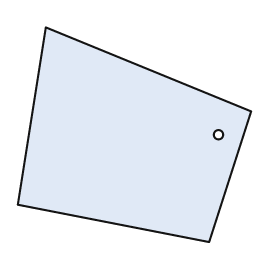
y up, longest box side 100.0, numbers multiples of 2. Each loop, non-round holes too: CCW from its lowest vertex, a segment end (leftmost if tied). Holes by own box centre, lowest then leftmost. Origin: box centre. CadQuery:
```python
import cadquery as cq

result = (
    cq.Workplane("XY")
    .moveTo(32.0, -46.0)
    .lineTo(50.0, 10.0)
    .lineTo(-38.0, 46.0)
    .lineTo(-50.0, -30.0)
    .close()
    .moveTo(36.0, 0.0)
    .circle(2.0)
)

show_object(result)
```